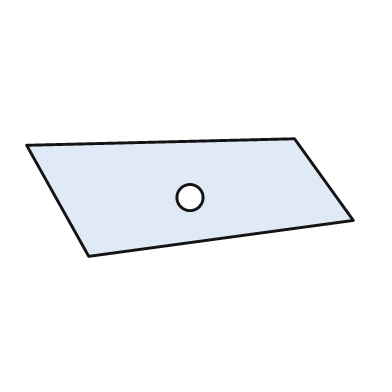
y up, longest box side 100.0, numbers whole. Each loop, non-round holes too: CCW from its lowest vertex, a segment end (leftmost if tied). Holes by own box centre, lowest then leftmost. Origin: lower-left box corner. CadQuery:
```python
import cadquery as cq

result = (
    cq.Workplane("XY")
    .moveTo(19.0, 0.0)
    .lineTo(100.0, 11.0)
    .lineTo(82.0, 36.0)
    .lineTo(0.0, 34.0)
    .close()
    .moveTo(50.0, 18.0)
    .circle(4.0)
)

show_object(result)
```